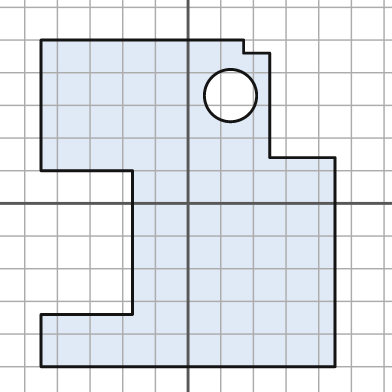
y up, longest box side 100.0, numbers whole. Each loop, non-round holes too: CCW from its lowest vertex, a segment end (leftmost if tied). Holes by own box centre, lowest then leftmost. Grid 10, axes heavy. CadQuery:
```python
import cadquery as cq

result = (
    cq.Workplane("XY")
    .moveTo(-45.0, -50.0)
    .lineTo(45.0, -50.0)
    .lineTo(45.0, 14.0)
    .lineTo(25.0, 14.0)
    .lineTo(25.0, 46.0)
    .lineTo(17.0, 46.0)
    .lineTo(17.0, 50.0)
    .lineTo(-45.0, 50.0)
    .lineTo(-45.0, 10.0)
    .lineTo(-17.0, 10.0)
    .lineTo(-17.0, -34.0)
    .lineTo(-45.0, -34.0)
    .close()
    .moveTo(13.0, 33.0)
    .circle(8.0)
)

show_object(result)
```